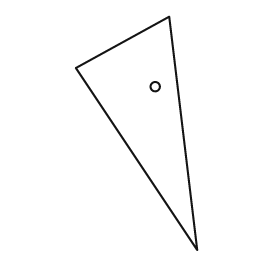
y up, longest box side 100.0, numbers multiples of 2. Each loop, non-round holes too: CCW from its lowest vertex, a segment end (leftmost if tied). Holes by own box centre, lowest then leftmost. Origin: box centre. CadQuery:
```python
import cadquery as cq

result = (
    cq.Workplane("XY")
    .moveTo(26.0, -50.0)
    .lineTo(14.0, 50.0)
    .lineTo(-26.0, 28.0)
    .close()
    .moveTo(8.0, 20.0)
    .circle(2.0)
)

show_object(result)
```